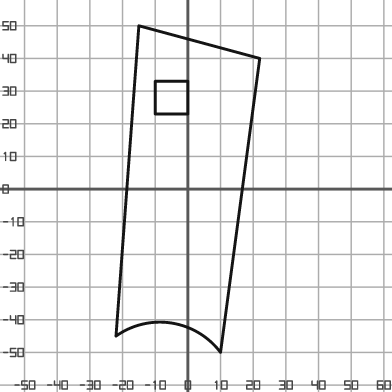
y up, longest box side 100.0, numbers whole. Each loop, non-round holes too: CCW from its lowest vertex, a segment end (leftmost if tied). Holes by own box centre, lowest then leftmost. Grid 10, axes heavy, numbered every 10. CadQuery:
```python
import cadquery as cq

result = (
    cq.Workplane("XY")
    .moveTo(10.0, -50.0)
    .lineTo(22.0, 40.0)
    .lineTo(-15.0, 50.0)
    .lineTo(-22.0, -45.0)
    .threePointArc((-5.0, -41.0), (10.0, -50.0))
    .close()
    .moveTo(-10.0, 23.0)
    .lineTo(0.0, 23.0)
    .lineTo(0.0, 33.0)
    .lineTo(-10.0, 33.0)
    .close()
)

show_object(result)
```